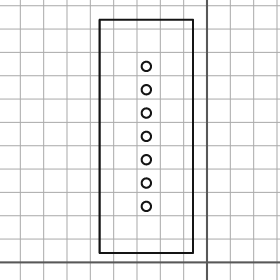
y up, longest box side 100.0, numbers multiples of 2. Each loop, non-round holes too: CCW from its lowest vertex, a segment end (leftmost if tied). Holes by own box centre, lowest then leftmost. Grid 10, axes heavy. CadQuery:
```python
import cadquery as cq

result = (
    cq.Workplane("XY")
    .moveTo(-46.0, 4.0)
    .lineTo(-6.0, 4.0)
    .lineTo(-6.0, 104.0)
    .lineTo(-46.0, 104.0)
    .close()
    .moveTo(-26.0, 24.0)
    .circle(2.0)
    .moveTo(-26.0, 34.0)
    .circle(2.0)
    .moveTo(-26.0, 44.0)
    .circle(2.0)
    .moveTo(-26.0, 54.0)
    .circle(2.0)
    .moveTo(-26.0, 64.0)
    .circle(2.0)
    .moveTo(-26.0, 74.0)
    .circle(2.0)
    .moveTo(-26.0, 84.0)
    .circle(2.0)
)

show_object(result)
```